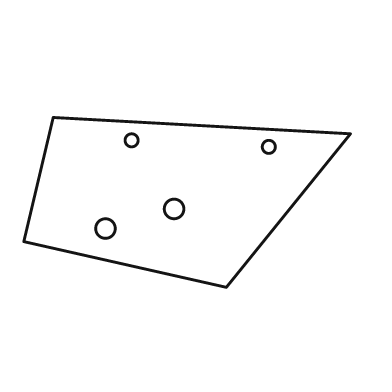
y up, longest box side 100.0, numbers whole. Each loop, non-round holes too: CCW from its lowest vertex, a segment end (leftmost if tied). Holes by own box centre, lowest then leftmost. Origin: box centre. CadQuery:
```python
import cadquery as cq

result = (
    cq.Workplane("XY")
    .moveTo(12.0, -26.0)
    .lineTo(50.0, 21.0)
    .lineTo(-41.0, 26.0)
    .lineTo(-50.0, -12.0)
    .close()
    .moveTo(-25.0, -8.0)
    .circle(3.0)
    .moveTo(-4.0, -2.0)
    .circle(3.0)
    .moveTo(25.0, 17.0)
    .circle(2.0)
    .moveTo(-17.0, 19.0)
    .circle(2.0)
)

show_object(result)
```